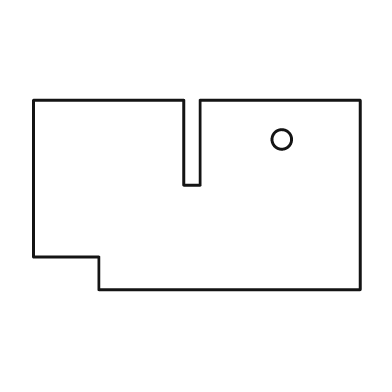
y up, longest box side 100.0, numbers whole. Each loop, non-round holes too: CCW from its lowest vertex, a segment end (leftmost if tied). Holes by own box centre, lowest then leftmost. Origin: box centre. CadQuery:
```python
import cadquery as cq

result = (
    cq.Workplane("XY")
    .moveTo(-30.0, -29.0)
    .lineTo(50.0, -29.0)
    .lineTo(50.0, 29.0)
    .lineTo(1.0, 29.0)
    .lineTo(1.0, 3.0)
    .lineTo(-4.0, 3.0)
    .lineTo(-4.0, 29.0)
    .lineTo(-50.0, 29.0)
    .lineTo(-50.0, -19.0)
    .lineTo(-30.0, -19.0)
    .close()
    .moveTo(26.0, 17.0)
    .circle(3.0)
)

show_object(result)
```